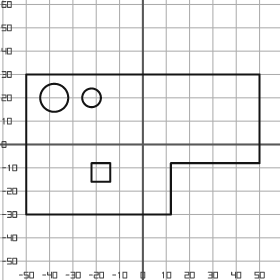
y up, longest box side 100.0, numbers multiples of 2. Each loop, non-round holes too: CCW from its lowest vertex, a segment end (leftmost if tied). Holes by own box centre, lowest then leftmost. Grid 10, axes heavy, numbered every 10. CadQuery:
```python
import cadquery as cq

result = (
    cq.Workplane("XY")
    .moveTo(-50.0, -30.0)
    .lineTo(12.0, -30.0)
    .lineTo(12.0, -8.0)
    .lineTo(50.0, -8.0)
    .lineTo(50.0, 30.0)
    .lineTo(-50.0, 30.0)
    .close()
    .moveTo(-22.0, -16.0)
    .lineTo(-14.0, -16.0)
    .lineTo(-14.0, -8.0)
    .lineTo(-22.0, -8.0)
    .close()
    .moveTo(-38.0, 20.0)
    .circle(6.0)
    .moveTo(-22.0, 20.0)
    .circle(4.0)
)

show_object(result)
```